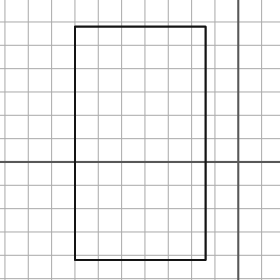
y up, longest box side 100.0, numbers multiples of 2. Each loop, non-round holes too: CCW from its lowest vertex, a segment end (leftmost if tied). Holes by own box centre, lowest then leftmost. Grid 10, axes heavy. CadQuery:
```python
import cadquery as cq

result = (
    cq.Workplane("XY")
    .moveTo(-70.0, -42.0)
    .lineTo(-14.0, -42.0)
    .lineTo(-14.0, 58.0)
    .lineTo(-70.0, 58.0)
    .close()
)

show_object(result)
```